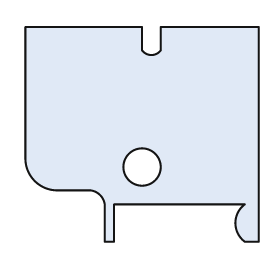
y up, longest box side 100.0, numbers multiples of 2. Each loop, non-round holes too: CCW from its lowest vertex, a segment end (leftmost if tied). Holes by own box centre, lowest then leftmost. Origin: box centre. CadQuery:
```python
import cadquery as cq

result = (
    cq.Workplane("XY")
    .moveTo(-16.0, -46.0)
    .lineTo(-12.0, -46.0)
    .lineTo(-12.0, -30.0)
    .lineTo(44.0, -30.0)
    .threePointArc((40.0, -38.0), (44.0, -46.0))
    .lineTo(50.0, -46.0)
    .lineTo(50.0, 46.0)
    .lineTo(8.0, 46.0)
    .lineTo(8.0, 36.0)
    .threePointArc((4.0, 34.0), (0.0, 36.0))
    .lineTo(0.0, 46.0)
    .lineTo(-50.0, 46.0)
    .lineTo(-50.0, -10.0)
    .threePointArc((-46.0, -20.0), (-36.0, -24.0))
    .lineTo(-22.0, -24.0)
    .threePointArc((-18.0, -26.0), (-16.0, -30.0))
    .close()
    .moveTo(0.0, -14.0)
    .circle(8.0)
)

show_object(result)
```